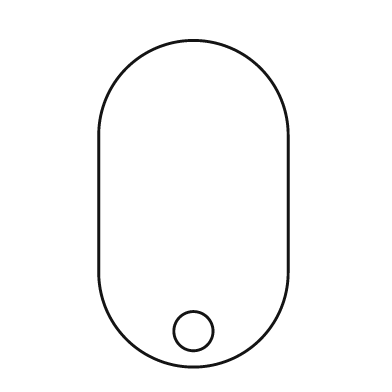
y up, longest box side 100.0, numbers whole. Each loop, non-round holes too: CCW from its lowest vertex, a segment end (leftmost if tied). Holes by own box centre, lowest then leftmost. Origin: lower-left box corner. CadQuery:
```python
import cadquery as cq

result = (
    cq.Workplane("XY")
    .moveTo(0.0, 29.0)
    .threePointArc((29.0, 0.0), (58.0, 29.0))
    .lineTo(58.0, 71.0)
    .threePointArc((29.0, 100.0), (0.0, 71.0))
    .close()
    .moveTo(29.0, 11.0)
    .circle(6.0)
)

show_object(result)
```